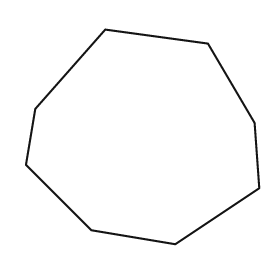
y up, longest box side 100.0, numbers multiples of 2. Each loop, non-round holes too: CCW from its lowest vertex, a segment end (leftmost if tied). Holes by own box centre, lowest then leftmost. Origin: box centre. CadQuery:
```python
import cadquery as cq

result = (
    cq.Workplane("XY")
    .moveTo(14.0, -46.0)
    .lineTo(50.0, -22.0)
    .lineTo(48.0, 6.0)
    .lineTo(28.0, 40.0)
    .lineTo(-16.0, 46.0)
    .lineTo(-46.0, 12.0)
    .lineTo(-50.0, -12.0)
    .lineTo(-22.0, -40.0)
    .close()
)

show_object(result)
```